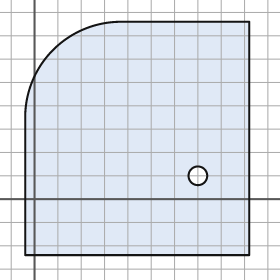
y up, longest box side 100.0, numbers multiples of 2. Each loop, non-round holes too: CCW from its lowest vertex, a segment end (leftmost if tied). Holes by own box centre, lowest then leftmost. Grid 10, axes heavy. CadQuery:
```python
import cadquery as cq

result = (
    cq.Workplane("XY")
    .moveTo(-4.0, -24.0)
    .lineTo(92.0, -24.0)
    .lineTo(92.0, 76.0)
    .lineTo(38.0, 76.0)
    .threePointArc((8.0, 64.0), (-4.0, 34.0))
    .close()
    .moveTo(70.0, 10.0)
    .circle(4.0)
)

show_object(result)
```